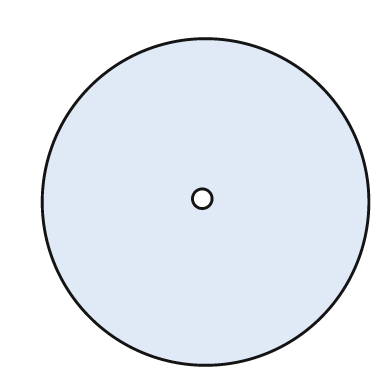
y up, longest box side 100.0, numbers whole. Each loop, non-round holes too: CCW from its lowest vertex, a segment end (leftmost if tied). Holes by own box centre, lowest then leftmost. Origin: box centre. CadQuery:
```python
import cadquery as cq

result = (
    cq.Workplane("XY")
    .moveTo(0.0, 0.0)
    .circle(50.0)
    .moveTo(-1.0, 1.0)
    .circle(3.0)
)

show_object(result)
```